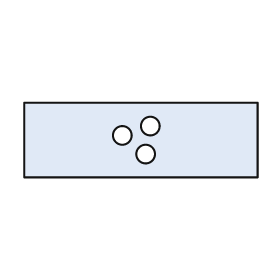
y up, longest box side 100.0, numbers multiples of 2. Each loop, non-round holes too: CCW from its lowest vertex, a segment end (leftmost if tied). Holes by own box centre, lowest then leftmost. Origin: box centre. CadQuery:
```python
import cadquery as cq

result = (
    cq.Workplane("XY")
    .moveTo(-50.0, -16.0)
    .lineTo(50.0, -16.0)
    .lineTo(50.0, 16.0)
    .lineTo(-50.0, 16.0)
    .close()
    .moveTo(2.0, -6.0)
    .circle(4.0)
    .moveTo(-8.0, 2.0)
    .circle(4.0)
    .moveTo(4.0, 6.0)
    .circle(4.0)
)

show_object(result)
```